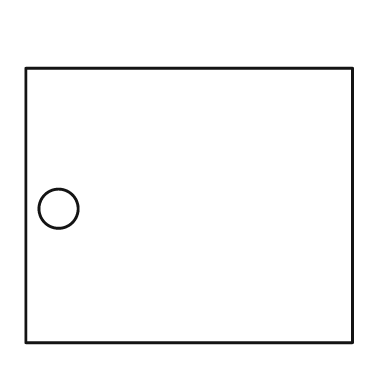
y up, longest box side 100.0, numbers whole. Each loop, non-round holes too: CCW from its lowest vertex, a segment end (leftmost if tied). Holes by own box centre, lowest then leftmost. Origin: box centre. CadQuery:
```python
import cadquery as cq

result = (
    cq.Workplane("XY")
    .moveTo(-50.0, -42.0)
    .lineTo(50.0, -42.0)
    .lineTo(50.0, 42.0)
    .lineTo(-50.0, 42.0)
    .close()
    .moveTo(-40.0, -1.0)
    .circle(6.0)
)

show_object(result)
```